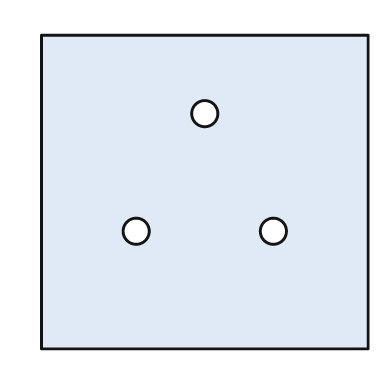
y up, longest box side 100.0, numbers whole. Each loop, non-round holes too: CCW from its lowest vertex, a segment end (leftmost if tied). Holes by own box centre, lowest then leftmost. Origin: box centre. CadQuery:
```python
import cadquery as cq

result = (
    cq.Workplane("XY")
    .moveTo(-50.0, -48.0)
    .lineTo(50.0, -48.0)
    .lineTo(50.0, 48.0)
    .lineTo(-50.0, 48.0)
    .close()
    .moveTo(-21.0, -12.0)
    .circle(4.0)
    .moveTo(21.0, -12.0)
    .circle(4.0)
    .moveTo(0.0, 24.0)
    .circle(4.0)
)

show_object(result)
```